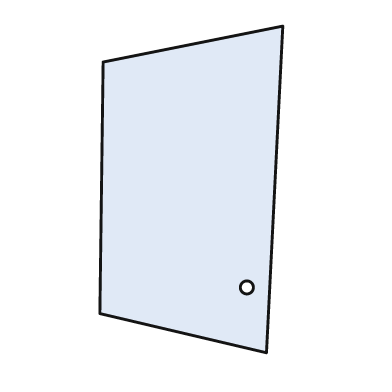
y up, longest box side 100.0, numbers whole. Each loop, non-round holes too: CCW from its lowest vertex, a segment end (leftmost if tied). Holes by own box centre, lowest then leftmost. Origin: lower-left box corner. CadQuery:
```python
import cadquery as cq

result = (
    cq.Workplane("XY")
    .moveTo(51.0, 0.0)
    .lineTo(56.0, 100.0)
    .lineTo(1.0, 89.0)
    .lineTo(0.0, 12.0)
    .close()
    .moveTo(45.0, 20.0)
    .circle(2.0)
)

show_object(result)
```